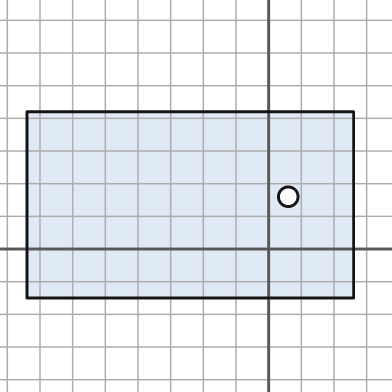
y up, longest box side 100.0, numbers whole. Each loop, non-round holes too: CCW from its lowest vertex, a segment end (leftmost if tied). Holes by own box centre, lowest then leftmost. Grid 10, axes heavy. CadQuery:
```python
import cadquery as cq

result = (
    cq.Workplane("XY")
    .moveTo(-74.0, -15.0)
    .lineTo(26.0, -15.0)
    .lineTo(26.0, 42.0)
    .lineTo(-74.0, 42.0)
    .close()
    .moveTo(6.0, 16.0)
    .circle(3.0)
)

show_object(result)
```